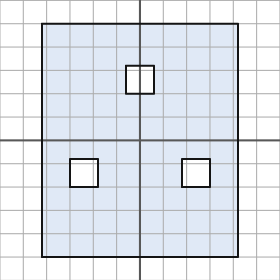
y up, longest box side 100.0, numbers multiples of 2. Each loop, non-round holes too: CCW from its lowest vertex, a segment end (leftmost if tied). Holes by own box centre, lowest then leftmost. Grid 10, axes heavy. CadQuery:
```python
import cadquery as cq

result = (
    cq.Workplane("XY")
    .moveTo(-42.0, -50.0)
    .lineTo(42.0, -50.0)
    .lineTo(42.0, 50.0)
    .lineTo(-42.0, 50.0)
    .close()
    .moveTo(-30.0, -20.0)
    .lineTo(-18.0, -20.0)
    .lineTo(-18.0, -8.0)
    .lineTo(-30.0, -8.0)
    .close()
    .moveTo(18.0, -20.0)
    .lineTo(30.0, -20.0)
    .lineTo(30.0, -8.0)
    .lineTo(18.0, -8.0)
    .close()
    .moveTo(-6.0, 20.0)
    .lineTo(6.0, 20.0)
    .lineTo(6.0, 32.0)
    .lineTo(-6.0, 32.0)
    .close()
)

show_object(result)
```